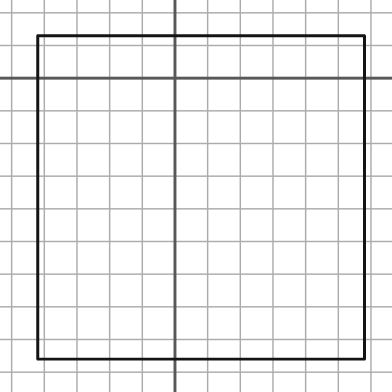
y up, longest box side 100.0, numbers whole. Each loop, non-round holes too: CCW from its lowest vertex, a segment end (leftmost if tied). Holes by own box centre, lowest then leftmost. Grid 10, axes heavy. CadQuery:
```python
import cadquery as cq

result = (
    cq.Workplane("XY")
    .moveTo(-42.0, -86.0)
    .lineTo(58.0, -86.0)
    .lineTo(58.0, 13.0)
    .lineTo(-42.0, 13.0)
    .close()
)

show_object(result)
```